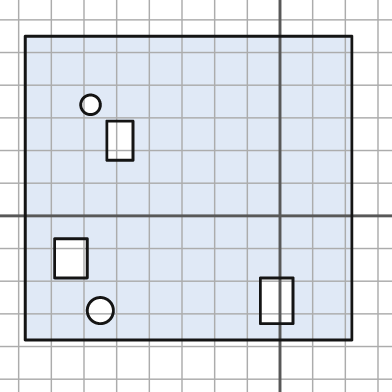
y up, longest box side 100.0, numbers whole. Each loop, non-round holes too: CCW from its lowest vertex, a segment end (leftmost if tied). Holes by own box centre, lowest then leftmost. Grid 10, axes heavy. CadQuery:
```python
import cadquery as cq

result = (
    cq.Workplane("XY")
    .moveTo(-78.0, -38.0)
    .lineTo(22.0, -38.0)
    .lineTo(22.0, 55.0)
    .lineTo(-78.0, 55.0)
    .close()
    .moveTo(-55.0, -29.0)
    .circle(4.0)
    .moveTo(-6.0, -33.0)
    .lineTo(4.0, -33.0)
    .lineTo(4.0, -19.0)
    .lineTo(-6.0, -19.0)
    .close()
    .moveTo(-69.0, -19.0)
    .lineTo(-59.0, -19.0)
    .lineTo(-59.0, -7.0)
    .lineTo(-69.0, -7.0)
    .close()
    .moveTo(-53.0, 17.0)
    .lineTo(-45.0, 17.0)
    .lineTo(-45.0, 29.0)
    .lineTo(-53.0, 29.0)
    .close()
    .moveTo(-58.0, 34.0)
    .circle(3.0)
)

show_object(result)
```